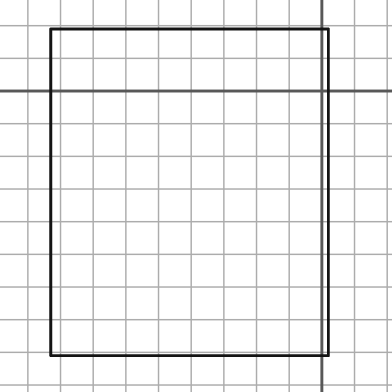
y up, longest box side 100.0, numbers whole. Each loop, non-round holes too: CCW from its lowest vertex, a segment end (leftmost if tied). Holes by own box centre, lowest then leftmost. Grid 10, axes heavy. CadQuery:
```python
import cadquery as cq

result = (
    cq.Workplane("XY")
    .moveTo(-83.0, -81.0)
    .lineTo(2.0, -81.0)
    .lineTo(2.0, 19.0)
    .lineTo(-83.0, 19.0)
    .close()
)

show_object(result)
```